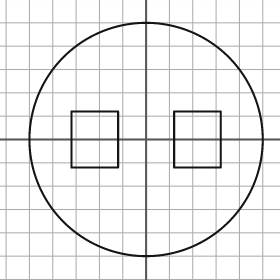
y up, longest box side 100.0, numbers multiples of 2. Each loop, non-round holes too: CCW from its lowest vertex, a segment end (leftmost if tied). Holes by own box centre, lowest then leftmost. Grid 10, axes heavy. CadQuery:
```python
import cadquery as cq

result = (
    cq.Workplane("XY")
    .moveTo(0.0, 0.0)
    .circle(50.0)
    .moveTo(-32.0, -12.0)
    .lineTo(-12.0, -12.0)
    .lineTo(-12.0, 12.0)
    .lineTo(-32.0, 12.0)
    .close()
    .moveTo(12.0, -12.0)
    .lineTo(32.0, -12.0)
    .lineTo(32.0, 12.0)
    .lineTo(12.0, 12.0)
    .close()
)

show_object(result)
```